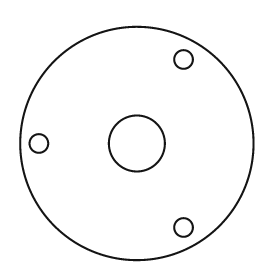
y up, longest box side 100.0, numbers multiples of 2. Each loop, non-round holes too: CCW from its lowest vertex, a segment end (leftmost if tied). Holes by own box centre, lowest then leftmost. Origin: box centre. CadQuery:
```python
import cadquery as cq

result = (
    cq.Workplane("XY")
    .moveTo(0.0, 0.0)
    .circle(50.0)
    .moveTo(20.0, -36.0)
    .circle(4.0)
    .moveTo(-42.0, 0.0)
    .circle(4.0)
    .moveTo(0.0, 0.0)
    .circle(12.0)
    .moveTo(20.0, 36.0)
    .circle(4.0)
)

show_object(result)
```